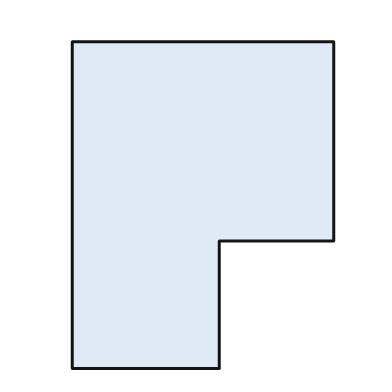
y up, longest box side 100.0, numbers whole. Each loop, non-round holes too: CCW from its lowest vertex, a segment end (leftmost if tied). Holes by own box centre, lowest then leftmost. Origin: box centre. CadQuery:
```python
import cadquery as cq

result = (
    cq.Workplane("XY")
    .moveTo(-40.0, -50.0)
    .lineTo(5.0, -50.0)
    .lineTo(5.0, -11.0)
    .lineTo(40.0, -11.0)
    .lineTo(40.0, 50.0)
    .lineTo(-40.0, 50.0)
    .close()
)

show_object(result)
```